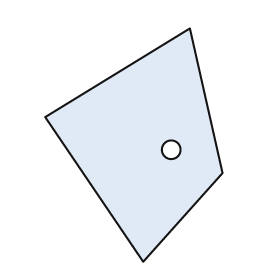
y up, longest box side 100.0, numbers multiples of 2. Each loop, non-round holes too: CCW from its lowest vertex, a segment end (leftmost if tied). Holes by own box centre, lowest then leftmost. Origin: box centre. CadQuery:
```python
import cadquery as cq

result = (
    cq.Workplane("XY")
    .moveTo(4.0, -50.0)
    .lineTo(38.0, -12.0)
    .lineTo(24.0, 50.0)
    .lineTo(-38.0, 12.0)
    .close()
    .moveTo(16.0, -2.0)
    .circle(4.0)
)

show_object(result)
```